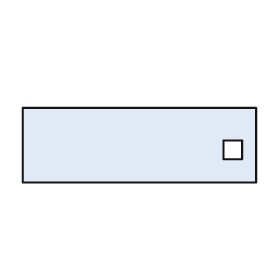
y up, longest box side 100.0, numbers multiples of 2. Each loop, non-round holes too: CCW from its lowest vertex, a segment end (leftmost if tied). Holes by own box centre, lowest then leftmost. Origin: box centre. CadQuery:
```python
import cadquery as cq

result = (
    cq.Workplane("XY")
    .moveTo(-50.0, -16.0)
    .lineTo(50.0, -16.0)
    .lineTo(50.0, 16.0)
    .lineTo(-50.0, 16.0)
    .close()
    .moveTo(36.0, -6.0)
    .lineTo(44.0, -6.0)
    .lineTo(44.0, 2.0)
    .lineTo(36.0, 2.0)
    .close()
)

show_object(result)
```